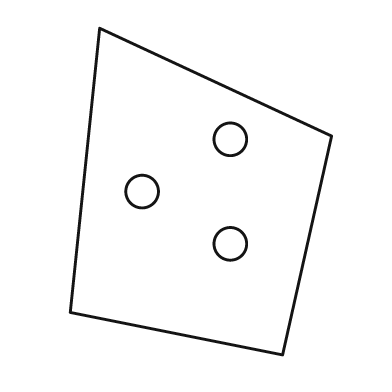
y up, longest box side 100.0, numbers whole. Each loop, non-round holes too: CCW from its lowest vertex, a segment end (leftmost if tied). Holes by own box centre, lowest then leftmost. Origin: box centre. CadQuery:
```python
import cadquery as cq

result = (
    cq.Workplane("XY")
    .moveTo(25.0, -50.0)
    .lineTo(40.0, 17.0)
    .lineTo(-31.0, 50.0)
    .lineTo(-40.0, -37.0)
    .close()
    .moveTo(9.0, -16.0)
    .circle(5.0)
    .moveTo(-18.0, 0.0)
    .circle(5.0)
    .moveTo(9.0, 16.0)
    .circle(5.0)
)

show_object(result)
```